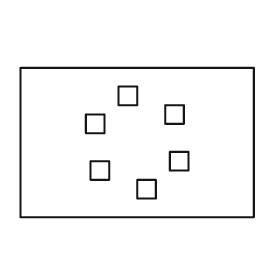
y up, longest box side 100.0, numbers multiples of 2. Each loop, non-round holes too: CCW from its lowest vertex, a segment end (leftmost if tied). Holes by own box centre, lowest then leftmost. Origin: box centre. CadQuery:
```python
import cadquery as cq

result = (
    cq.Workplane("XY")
    .moveTo(-50.0, -32.0)
    .lineTo(50.0, -32.0)
    .lineTo(50.0, 32.0)
    .lineTo(-50.0, 32.0)
    .close()
    .moveTo(0.0, -24.0)
    .lineTo(8.0, -24.0)
    .lineTo(8.0, -16.0)
    .lineTo(0.0, -16.0)
    .close()
    .moveTo(-20.0, -16.0)
    .lineTo(-12.0, -16.0)
    .lineTo(-12.0, -8.0)
    .lineTo(-20.0, -8.0)
    .close()
    .moveTo(14.0, -12.0)
    .lineTo(22.0, -12.0)
    .lineTo(22.0, -4.0)
    .lineTo(14.0, -4.0)
    .close()
    .moveTo(-22.0, 4.0)
    .lineTo(-14.0, 4.0)
    .lineTo(-14.0, 12.0)
    .lineTo(-22.0, 12.0)
    .close()
    .moveTo(12.0, 8.0)
    .lineTo(20.0, 8.0)
    .lineTo(20.0, 16.0)
    .lineTo(12.0, 16.0)
    .close()
    .moveTo(-8.0, 16.0)
    .lineTo(0.0, 16.0)
    .lineTo(0.0, 24.0)
    .lineTo(-8.0, 24.0)
    .close()
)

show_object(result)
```